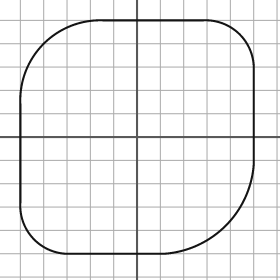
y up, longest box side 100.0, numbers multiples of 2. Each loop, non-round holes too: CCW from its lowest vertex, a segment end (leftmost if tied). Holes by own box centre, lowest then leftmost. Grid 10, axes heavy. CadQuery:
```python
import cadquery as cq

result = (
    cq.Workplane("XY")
    .moveTo(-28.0, -50.0)
    .lineTo(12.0, -50.0)
    .threePointArc((38.0, -38.0), (50.0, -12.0))
    .lineTo(50.0, 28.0)
    .threePointArc((44.0, 44.0), (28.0, 50.0))
    .lineTo(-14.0, 50.0)
    .threePointArc((-40.0, 40.0), (-50.0, 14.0))
    .lineTo(-50.0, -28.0)
    .threePointArc((-44.0, -44.0), (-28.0, -50.0))
    .close()
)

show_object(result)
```